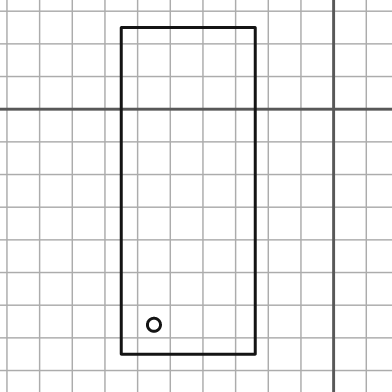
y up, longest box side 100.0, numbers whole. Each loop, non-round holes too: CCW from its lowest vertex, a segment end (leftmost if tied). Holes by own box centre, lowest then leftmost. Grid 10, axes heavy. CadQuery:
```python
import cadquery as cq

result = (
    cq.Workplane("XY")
    .moveTo(-65.0, -75.0)
    .lineTo(-24.0, -75.0)
    .lineTo(-24.0, 25.0)
    .lineTo(-65.0, 25.0)
    .close()
    .moveTo(-55.0, -66.0)
    .circle(2.0)
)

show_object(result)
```